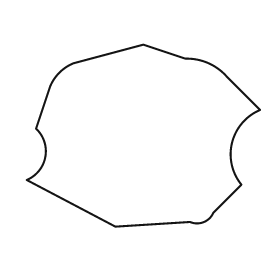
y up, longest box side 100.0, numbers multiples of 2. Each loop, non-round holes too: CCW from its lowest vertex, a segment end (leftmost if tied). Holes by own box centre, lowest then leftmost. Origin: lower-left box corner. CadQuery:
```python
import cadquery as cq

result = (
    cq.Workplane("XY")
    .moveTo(38.0, 0.0)
    .lineTo(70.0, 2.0)
    .threePointArc((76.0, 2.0), (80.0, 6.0))
    .lineTo(92.0, 18.0)
    .threePointArc((88.0, 36.0), (100.0, 50.0))
    .lineTo(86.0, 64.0)
    .threePointArc((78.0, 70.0), (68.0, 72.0))
    .lineTo(50.0, 78.0)
    .lineTo(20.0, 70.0)
    .threePointArc((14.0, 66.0), (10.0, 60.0))
    .lineTo(4.0, 42.0)
    .threePointArc((8.0, 30.0), (0.0, 20.0))
    .close()
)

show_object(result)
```